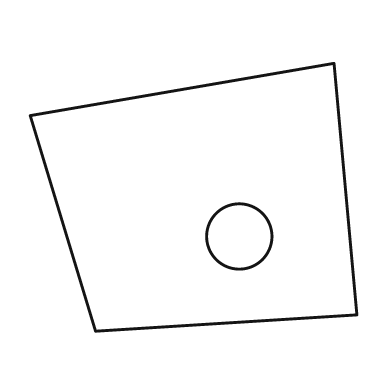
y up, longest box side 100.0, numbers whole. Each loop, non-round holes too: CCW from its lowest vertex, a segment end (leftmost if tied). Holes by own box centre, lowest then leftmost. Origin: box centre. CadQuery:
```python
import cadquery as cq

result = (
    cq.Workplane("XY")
    .moveTo(-30.0, -41.0)
    .lineTo(50.0, -36.0)
    .lineTo(43.0, 41.0)
    .lineTo(-50.0, 25.0)
    .close()
    .moveTo(14.0, -12.0)
    .circle(10.0)
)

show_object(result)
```